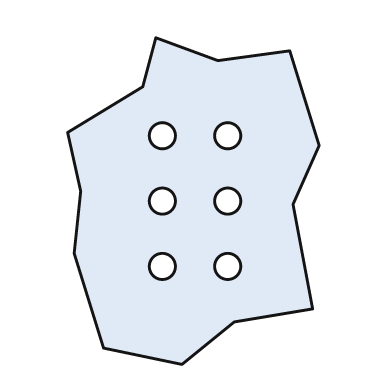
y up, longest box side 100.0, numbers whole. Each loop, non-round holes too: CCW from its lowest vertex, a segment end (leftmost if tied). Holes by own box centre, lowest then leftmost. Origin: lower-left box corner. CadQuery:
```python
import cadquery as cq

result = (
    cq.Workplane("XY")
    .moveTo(35.0, 0.0)
    .lineTo(51.0, 13.0)
    .lineTo(75.0, 17.0)
    .lineTo(69.0, 49.0)
    .lineTo(77.0, 67.0)
    .lineTo(68.0, 96.0)
    .lineTo(46.0, 93.0)
    .lineTo(27.0, 100.0)
    .lineTo(23.0, 85.0)
    .lineTo(0.0, 71.0)
    .lineTo(4.0, 53.0)
    .lineTo(2.0, 34.0)
    .lineTo(11.0, 5.0)
    .close()
    .moveTo(29.0, 30.0)
    .circle(4.0)
    .moveTo(49.0, 30.0)
    .circle(4.0)
    .moveTo(29.0, 50.0)
    .circle(4.0)
    .moveTo(49.0, 50.0)
    .circle(4.0)
    .moveTo(29.0, 70.0)
    .circle(4.0)
    .moveTo(49.0, 70.0)
    .circle(4.0)
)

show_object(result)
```